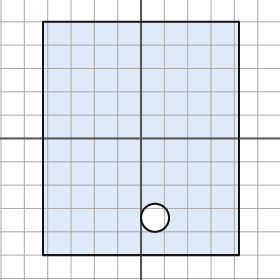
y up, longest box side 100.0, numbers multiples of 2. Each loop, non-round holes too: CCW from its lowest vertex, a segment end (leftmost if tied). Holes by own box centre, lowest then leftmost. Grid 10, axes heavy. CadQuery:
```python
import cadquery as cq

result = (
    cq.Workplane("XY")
    .moveTo(-42.0, -50.0)
    .lineTo(42.0, -50.0)
    .lineTo(42.0, 50.0)
    .lineTo(-42.0, 50.0)
    .close()
    .moveTo(6.0, -34.0)
    .circle(6.0)
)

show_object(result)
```